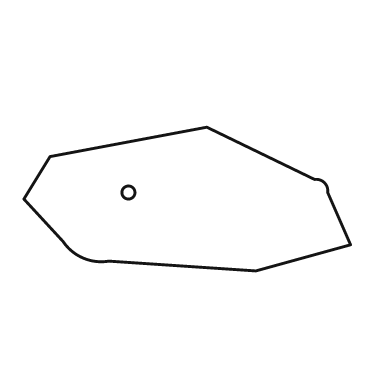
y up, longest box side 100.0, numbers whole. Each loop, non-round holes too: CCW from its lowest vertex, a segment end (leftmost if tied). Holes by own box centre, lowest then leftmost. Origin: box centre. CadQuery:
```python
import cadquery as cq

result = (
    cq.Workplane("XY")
    .moveTo(21.0, -22.0)
    .lineTo(50.0, -14.0)
    .lineTo(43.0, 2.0)
    .threePointArc((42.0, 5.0), (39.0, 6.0))
    .lineTo(6.0, 22.0)
    .lineTo(-42.0, 13.0)
    .lineTo(-50.0, 0.0)
    .lineTo(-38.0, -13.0)
    .threePointArc((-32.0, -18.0), (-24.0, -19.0))
    .close()
    .moveTo(-18.0, 2.0)
    .circle(2.0)
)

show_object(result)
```